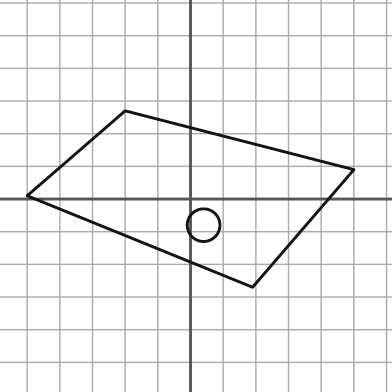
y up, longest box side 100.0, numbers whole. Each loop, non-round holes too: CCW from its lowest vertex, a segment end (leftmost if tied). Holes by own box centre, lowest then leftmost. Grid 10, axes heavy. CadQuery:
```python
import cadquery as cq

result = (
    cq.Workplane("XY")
    .moveTo(19.0, -27.0)
    .lineTo(50.0, 9.0)
    .lineTo(-20.0, 27.0)
    .lineTo(-50.0, 1.0)
    .close()
    .moveTo(4.0, -8.0)
    .circle(5.0)
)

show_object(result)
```